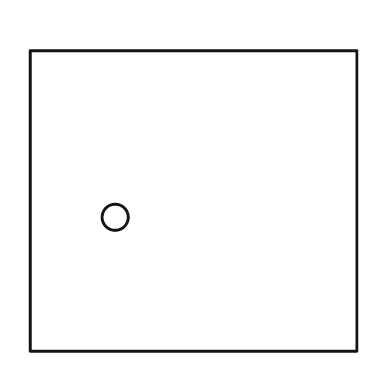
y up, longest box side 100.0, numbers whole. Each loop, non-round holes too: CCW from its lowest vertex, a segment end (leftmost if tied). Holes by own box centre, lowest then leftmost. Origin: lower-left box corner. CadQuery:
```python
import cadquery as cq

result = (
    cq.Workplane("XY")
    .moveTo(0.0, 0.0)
    .lineTo(100.0, 0.0)
    .lineTo(100.0, 92.0)
    .lineTo(0.0, 92.0)
    .close()
    .moveTo(26.0, 41.0)
    .circle(4.0)
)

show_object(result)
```